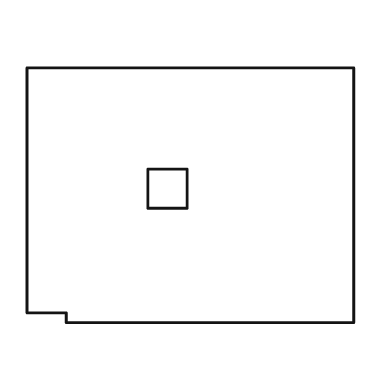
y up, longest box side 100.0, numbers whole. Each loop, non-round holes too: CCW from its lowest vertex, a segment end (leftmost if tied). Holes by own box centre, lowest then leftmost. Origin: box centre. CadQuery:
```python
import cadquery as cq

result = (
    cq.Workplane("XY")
    .moveTo(-38.0, -39.0)
    .lineTo(50.0, -39.0)
    .lineTo(50.0, 39.0)
    .lineTo(-50.0, 39.0)
    .lineTo(-50.0, -36.0)
    .lineTo(-38.0, -36.0)
    .close()
    .moveTo(-13.0, -4.0)
    .lineTo(-1.0, -4.0)
    .lineTo(-1.0, 8.0)
    .lineTo(-13.0, 8.0)
    .close()
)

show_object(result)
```